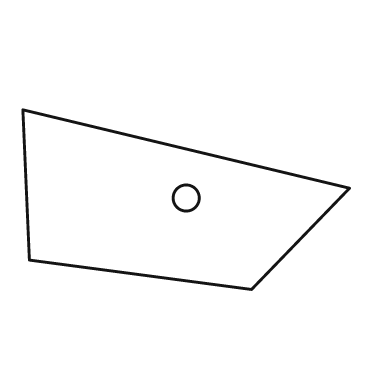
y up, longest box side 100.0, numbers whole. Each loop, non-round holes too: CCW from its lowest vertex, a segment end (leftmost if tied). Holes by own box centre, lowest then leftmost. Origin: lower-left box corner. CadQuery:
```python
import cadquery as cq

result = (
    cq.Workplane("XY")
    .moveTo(70.0, 0.0)
    .lineTo(100.0, 31.0)
    .lineTo(0.0, 55.0)
    .lineTo(2.0, 9.0)
    .close()
    .moveTo(50.0, 28.0)
    .circle(4.0)
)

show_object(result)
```